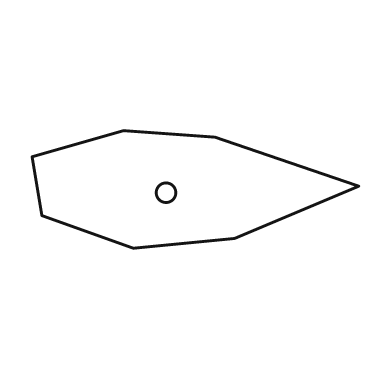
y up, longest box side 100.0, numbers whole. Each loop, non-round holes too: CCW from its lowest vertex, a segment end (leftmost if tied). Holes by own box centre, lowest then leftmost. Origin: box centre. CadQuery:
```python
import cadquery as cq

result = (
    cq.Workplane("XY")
    .moveTo(-19.0, -18.0)
    .lineTo(12.0, -15.0)
    .lineTo(50.0, 1.0)
    .lineTo(6.0, 16.0)
    .lineTo(-22.0, 18.0)
    .lineTo(-50.0, 10.0)
    .lineTo(-47.0, -8.0)
    .close()
    .moveTo(-9.0, -1.0)
    .circle(3.0)
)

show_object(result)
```